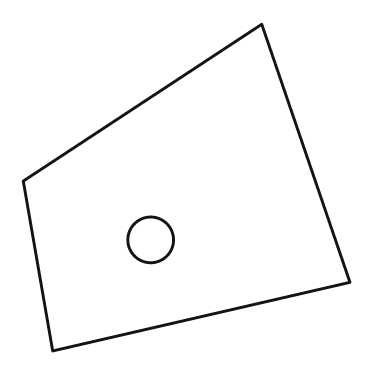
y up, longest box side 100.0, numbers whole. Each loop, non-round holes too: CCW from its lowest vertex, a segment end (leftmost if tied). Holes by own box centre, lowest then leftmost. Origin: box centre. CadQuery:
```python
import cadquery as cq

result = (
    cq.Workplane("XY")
    .moveTo(-41.0, -50.0)
    .lineTo(50.0, -29.0)
    .lineTo(23.0, 50.0)
    .lineTo(-50.0, 2.0)
    .close()
    .moveTo(-11.0, -16.0)
    .circle(7.0)
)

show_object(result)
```